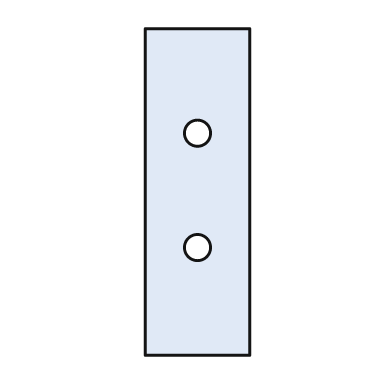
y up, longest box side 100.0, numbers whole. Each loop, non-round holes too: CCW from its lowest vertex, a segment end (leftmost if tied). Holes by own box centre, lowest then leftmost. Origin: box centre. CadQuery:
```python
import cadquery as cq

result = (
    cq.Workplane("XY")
    .moveTo(-16.0, -50.0)
    .lineTo(16.0, -50.0)
    .lineTo(16.0, 50.0)
    .lineTo(-16.0, 50.0)
    .close()
    .moveTo(0.0, -17.0)
    .circle(4.0)
    .moveTo(0.0, 18.0)
    .circle(4.0)
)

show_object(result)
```